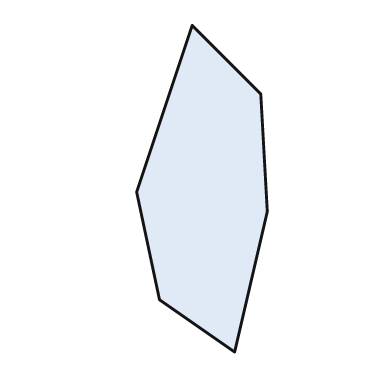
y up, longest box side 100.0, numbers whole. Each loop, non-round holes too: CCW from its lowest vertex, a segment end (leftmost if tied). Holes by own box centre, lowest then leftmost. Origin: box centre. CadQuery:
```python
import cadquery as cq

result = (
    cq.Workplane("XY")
    .moveTo(10.0, -50.0)
    .lineTo(20.0, -7.0)
    .lineTo(18.0, 29.0)
    .lineTo(-3.0, 50.0)
    .lineTo(-20.0, -1.0)
    .lineTo(-13.0, -34.0)
    .close()
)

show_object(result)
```